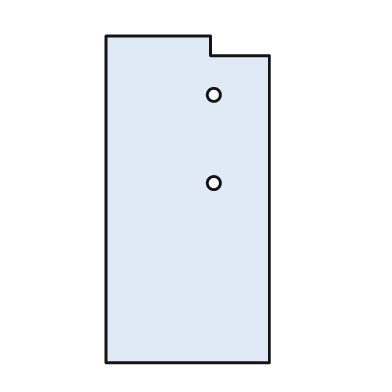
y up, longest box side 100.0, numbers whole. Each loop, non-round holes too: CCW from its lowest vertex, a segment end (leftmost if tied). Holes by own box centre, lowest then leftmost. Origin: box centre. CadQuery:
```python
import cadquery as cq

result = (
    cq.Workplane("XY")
    .moveTo(-25.0, -50.0)
    .lineTo(25.0, -50.0)
    .lineTo(25.0, 44.0)
    .lineTo(7.0, 44.0)
    .lineTo(7.0, 50.0)
    .lineTo(-25.0, 50.0)
    .close()
    .moveTo(8.0, 5.0)
    .circle(2.0)
    .moveTo(8.0, 32.0)
    .circle(2.0)
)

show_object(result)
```